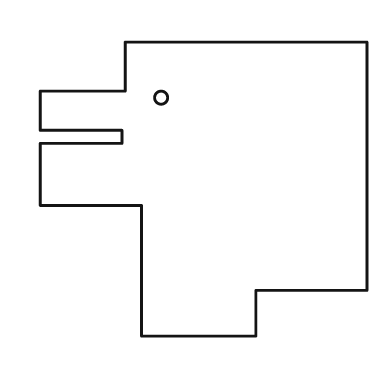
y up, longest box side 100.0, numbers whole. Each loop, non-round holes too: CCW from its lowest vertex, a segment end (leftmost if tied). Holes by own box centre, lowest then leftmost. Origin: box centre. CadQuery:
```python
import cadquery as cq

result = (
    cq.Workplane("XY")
    .moveTo(-19.0, -45.0)
    .lineTo(16.0, -45.0)
    .lineTo(16.0, -31.0)
    .lineTo(50.0, -31.0)
    .lineTo(50.0, 45.0)
    .lineTo(-24.0, 45.0)
    .lineTo(-24.0, 30.0)
    .lineTo(-50.0, 30.0)
    .lineTo(-50.0, 18.0)
    .lineTo(-25.0, 18.0)
    .lineTo(-25.0, 14.0)
    .lineTo(-50.0, 14.0)
    .lineTo(-50.0, -5.0)
    .lineTo(-19.0, -5.0)
    .close()
    .moveTo(-13.0, 28.0)
    .circle(2.0)
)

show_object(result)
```